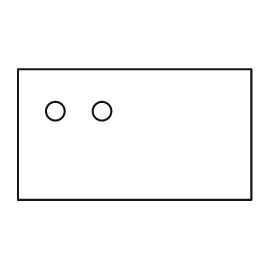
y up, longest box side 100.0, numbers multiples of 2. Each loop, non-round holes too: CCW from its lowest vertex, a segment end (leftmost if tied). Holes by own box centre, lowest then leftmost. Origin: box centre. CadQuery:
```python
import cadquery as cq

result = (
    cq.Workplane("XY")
    .moveTo(-50.0, -28.0)
    .lineTo(50.0, -28.0)
    .lineTo(50.0, 28.0)
    .lineTo(-50.0, 28.0)
    .close()
    .moveTo(-34.0, 10.0)
    .circle(4.0)
    .moveTo(-14.0, 10.0)
    .circle(4.0)
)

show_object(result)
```